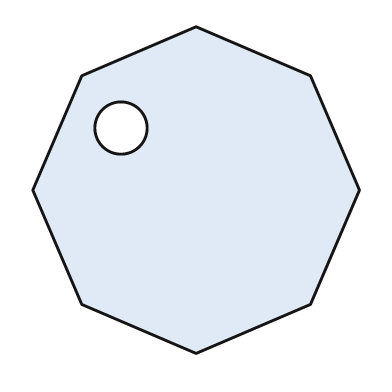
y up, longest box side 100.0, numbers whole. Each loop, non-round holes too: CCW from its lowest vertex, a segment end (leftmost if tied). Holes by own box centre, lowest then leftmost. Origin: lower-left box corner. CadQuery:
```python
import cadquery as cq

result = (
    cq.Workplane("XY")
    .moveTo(50.0, 0.0)
    .lineTo(85.0, 15.0)
    .lineTo(100.0, 50.0)
    .lineTo(85.0, 85.0)
    .lineTo(50.0, 100.0)
    .lineTo(15.0, 85.0)
    .lineTo(0.0, 50.0)
    .lineTo(15.0, 15.0)
    .close()
    .moveTo(27.0, 69.0)
    .circle(8.0)
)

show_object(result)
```